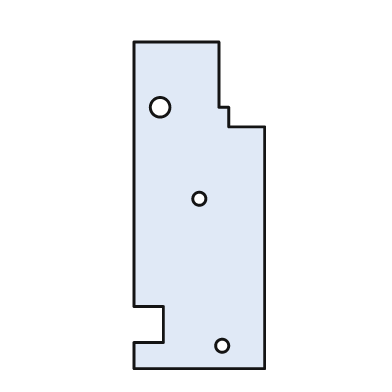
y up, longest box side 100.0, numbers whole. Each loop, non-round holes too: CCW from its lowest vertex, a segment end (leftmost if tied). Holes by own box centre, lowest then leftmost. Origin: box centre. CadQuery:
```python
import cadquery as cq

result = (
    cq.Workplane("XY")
    .moveTo(-20.0, -50.0)
    .lineTo(20.0, -50.0)
    .lineTo(20.0, 24.0)
    .lineTo(9.0, 24.0)
    .lineTo(9.0, 30.0)
    .lineTo(6.0, 30.0)
    .lineTo(6.0, 50.0)
    .lineTo(-20.0, 50.0)
    .lineTo(-20.0, -31.0)
    .lineTo(-11.0, -31.0)
    .lineTo(-11.0, -42.0)
    .lineTo(-20.0, -42.0)
    .close()
    .moveTo(7.0, -43.0)
    .circle(2.0)
    .moveTo(0.0, 2.0)
    .circle(2.0)
    .moveTo(-12.0, 30.0)
    .circle(3.0)
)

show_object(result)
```